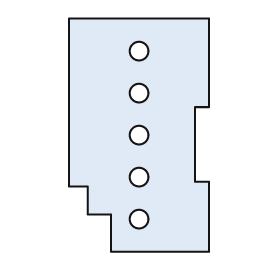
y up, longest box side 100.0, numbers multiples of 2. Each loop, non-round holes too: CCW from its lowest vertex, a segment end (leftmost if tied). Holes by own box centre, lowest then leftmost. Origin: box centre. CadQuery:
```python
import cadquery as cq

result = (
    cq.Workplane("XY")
    .moveTo(-12.0, -50.0)
    .lineTo(30.0, -50.0)
    .lineTo(30.0, -20.0)
    .lineTo(24.0, -20.0)
    .lineTo(24.0, 12.0)
    .lineTo(30.0, 12.0)
    .lineTo(30.0, 50.0)
    .lineTo(-30.0, 50.0)
    .lineTo(-30.0, -22.0)
    .lineTo(-22.0, -22.0)
    .lineTo(-22.0, -34.0)
    .lineTo(-12.0, -34.0)
    .close()
    .moveTo(0.0, -36.0)
    .circle(4.0)
    .moveTo(0.0, -18.0)
    .circle(4.0)
    .moveTo(0.0, 0.0)
    .circle(4.0)
    .moveTo(0.0, 18.0)
    .circle(4.0)
    .moveTo(0.0, 36.0)
    .circle(4.0)
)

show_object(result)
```